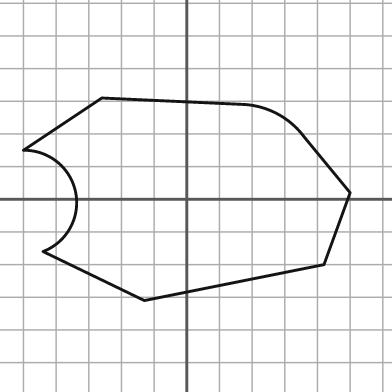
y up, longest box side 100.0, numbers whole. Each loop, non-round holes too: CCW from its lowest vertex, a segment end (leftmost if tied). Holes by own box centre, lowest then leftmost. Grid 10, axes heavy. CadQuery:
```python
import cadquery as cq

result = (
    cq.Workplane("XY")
    .moveTo(-13.0, -31.0)
    .lineTo(42.0, -20.0)
    .lineTo(50.0, 2.0)
    .lineTo(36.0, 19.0)
    .threePointArc((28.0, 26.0), (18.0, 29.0))
    .lineTo(-26.0, 31.0)
    .lineTo(-50.0, 15.0)
    .threePointArc((-34.0, 2.0), (-44.0, -16.0))
    .close()
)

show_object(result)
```